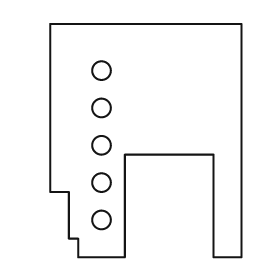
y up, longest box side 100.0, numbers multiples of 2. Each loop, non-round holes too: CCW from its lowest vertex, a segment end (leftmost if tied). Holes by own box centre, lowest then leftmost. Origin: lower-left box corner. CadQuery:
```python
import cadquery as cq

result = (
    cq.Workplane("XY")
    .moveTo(12.0, 0.0)
    .lineTo(32.0, 0.0)
    .lineTo(32.0, 44.0)
    .lineTo(70.0, 44.0)
    .lineTo(70.0, 0.0)
    .lineTo(82.0, 0.0)
    .lineTo(82.0, 100.0)
    .lineTo(0.0, 100.0)
    .lineTo(0.0, 28.0)
    .lineTo(8.0, 28.0)
    .lineTo(8.0, 8.0)
    .lineTo(12.0, 8.0)
    .close()
    .moveTo(22.0, 16.0)
    .circle(4.0)
    .moveTo(22.0, 32.0)
    .circle(4.0)
    .moveTo(22.0, 48.0)
    .circle(4.0)
    .moveTo(22.0, 64.0)
    .circle(4.0)
    .moveTo(22.0, 80.0)
    .circle(4.0)
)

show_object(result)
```